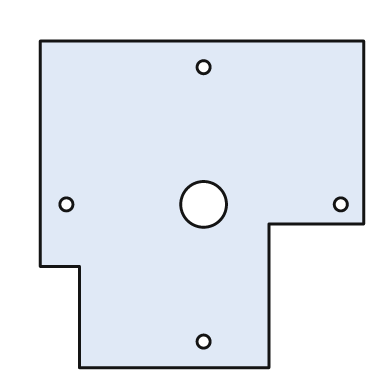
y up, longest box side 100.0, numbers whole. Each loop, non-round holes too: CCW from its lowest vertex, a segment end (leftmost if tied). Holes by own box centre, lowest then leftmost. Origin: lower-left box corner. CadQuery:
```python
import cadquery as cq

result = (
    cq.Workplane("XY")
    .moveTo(12.0, 0.0)
    .lineTo(70.0, 0.0)
    .lineTo(70.0, 44.0)
    .lineTo(99.0, 44.0)
    .lineTo(99.0, 100.0)
    .lineTo(0.0, 100.0)
    .lineTo(0.0, 31.0)
    .lineTo(12.0, 31.0)
    .close()
    .moveTo(50.0, 8.0)
    .circle(2.0)
    .moveTo(8.0, 50.0)
    .circle(2.0)
    .moveTo(50.0, 50.0)
    .circle(7.0)
    .moveTo(92.0, 50.0)
    .circle(2.0)
    .moveTo(50.0, 92.0)
    .circle(2.0)
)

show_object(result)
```